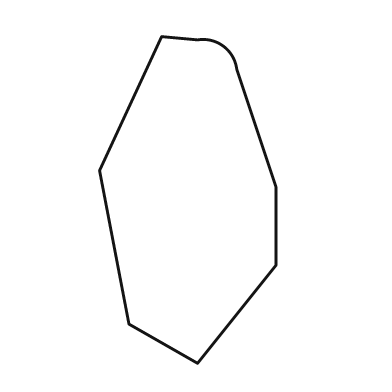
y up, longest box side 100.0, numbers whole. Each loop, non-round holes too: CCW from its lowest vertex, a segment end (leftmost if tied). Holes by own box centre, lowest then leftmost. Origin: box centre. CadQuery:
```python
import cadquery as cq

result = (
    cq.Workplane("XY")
    .moveTo(3.0, -50.0)
    .lineTo(27.0, -20.0)
    .lineTo(27.0, 4.0)
    .lineTo(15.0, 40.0)
    .threePointArc((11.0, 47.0), (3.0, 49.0))
    .lineTo(-8.0, 50.0)
    .lineTo(-27.0, 9.0)
    .lineTo(-18.0, -38.0)
    .close()
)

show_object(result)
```